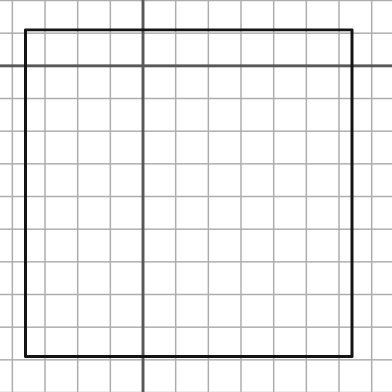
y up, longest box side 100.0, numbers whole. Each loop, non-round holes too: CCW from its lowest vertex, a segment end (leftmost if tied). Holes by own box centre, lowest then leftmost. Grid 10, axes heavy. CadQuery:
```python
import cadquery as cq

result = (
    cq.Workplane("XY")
    .moveTo(-36.0, -89.0)
    .lineTo(64.0, -89.0)
    .lineTo(64.0, 11.0)
    .lineTo(-36.0, 11.0)
    .close()
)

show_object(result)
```